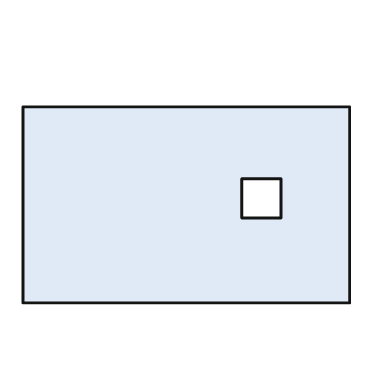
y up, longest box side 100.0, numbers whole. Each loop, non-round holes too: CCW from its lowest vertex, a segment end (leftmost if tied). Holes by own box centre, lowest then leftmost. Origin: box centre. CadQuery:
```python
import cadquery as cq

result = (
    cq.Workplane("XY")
    .moveTo(-50.0, -30.0)
    .lineTo(50.0, -30.0)
    .lineTo(50.0, 30.0)
    .lineTo(-50.0, 30.0)
    .close()
    .moveTo(17.0, -4.0)
    .lineTo(29.0, -4.0)
    .lineTo(29.0, 8.0)
    .lineTo(17.0, 8.0)
    .close()
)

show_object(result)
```